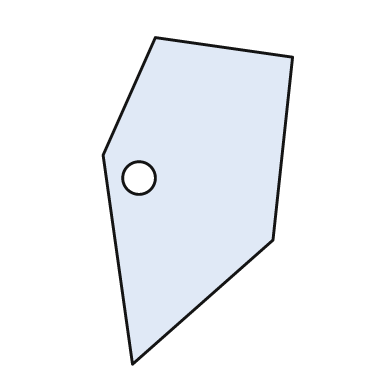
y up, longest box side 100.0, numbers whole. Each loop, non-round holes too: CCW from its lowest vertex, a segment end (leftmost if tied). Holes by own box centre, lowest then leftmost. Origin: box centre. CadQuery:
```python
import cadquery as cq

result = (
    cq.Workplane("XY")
    .moveTo(-20.0, -50.0)
    .lineTo(23.0, -12.0)
    .lineTo(29.0, 44.0)
    .lineTo(-13.0, 50.0)
    .lineTo(-29.0, 14.0)
    .close()
    .moveTo(-18.0, 7.0)
    .circle(5.0)
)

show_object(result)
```